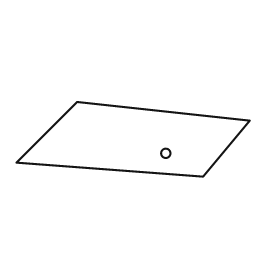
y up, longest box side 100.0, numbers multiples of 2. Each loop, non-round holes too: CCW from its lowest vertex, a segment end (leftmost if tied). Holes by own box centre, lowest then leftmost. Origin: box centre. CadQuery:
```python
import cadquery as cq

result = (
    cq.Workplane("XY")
    .moveTo(30.0, -16.0)
    .lineTo(50.0, 8.0)
    .lineTo(-24.0, 16.0)
    .lineTo(-50.0, -10.0)
    .close()
    .moveTo(14.0, -6.0)
    .circle(2.0)
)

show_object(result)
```